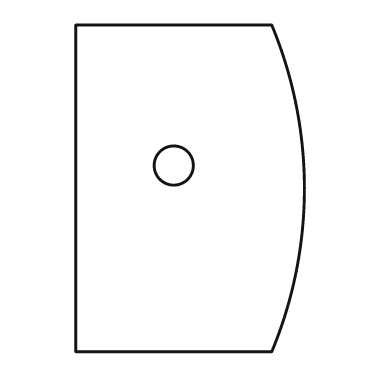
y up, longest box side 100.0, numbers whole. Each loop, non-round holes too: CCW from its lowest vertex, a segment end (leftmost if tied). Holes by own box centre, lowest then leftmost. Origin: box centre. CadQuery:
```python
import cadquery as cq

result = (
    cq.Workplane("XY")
    .moveTo(-35.0, -50.0)
    .lineTo(25.0, -50.0)
    .threePointArc((35.0, 0.0), (25.0, 50.0))
    .lineTo(-35.0, 50.0)
    .close()
    .moveTo(-5.0, 7.0)
    .circle(6.0)
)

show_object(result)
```